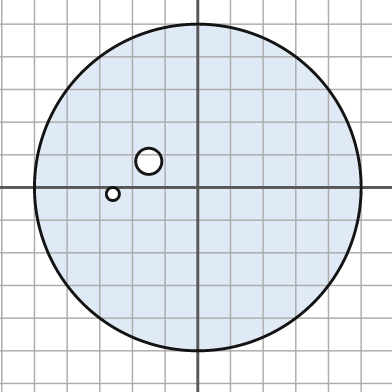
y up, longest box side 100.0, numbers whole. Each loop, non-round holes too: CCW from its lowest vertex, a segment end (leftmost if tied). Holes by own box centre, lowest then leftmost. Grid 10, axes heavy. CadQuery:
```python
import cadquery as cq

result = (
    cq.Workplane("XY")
    .moveTo(0.0, 0.0)
    .circle(50.0)
    .moveTo(-26.0, -2.0)
    .circle(2.0)
    .moveTo(-15.0, 8.0)
    .circle(4.0)
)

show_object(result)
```